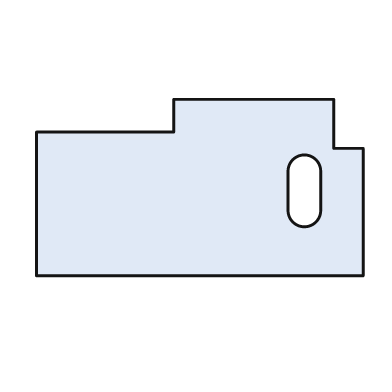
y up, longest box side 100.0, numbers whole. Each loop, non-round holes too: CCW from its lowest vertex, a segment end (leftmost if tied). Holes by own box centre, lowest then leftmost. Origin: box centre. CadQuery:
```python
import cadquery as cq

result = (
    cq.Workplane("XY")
    .moveTo(-50.0, -27.0)
    .lineTo(50.0, -27.0)
    .lineTo(50.0, 12.0)
    .lineTo(41.0, 12.0)
    .lineTo(41.0, 27.0)
    .lineTo(-8.0, 27.0)
    .lineTo(-8.0, 17.0)
    .lineTo(-50.0, 17.0)
    .close()
    .moveTo(27.0, -7.0)
    .threePointArc((32.0, -12.0), (37.0, -7.0))
    .lineTo(37.0, 5.0)
    .threePointArc((32.0, 10.0), (27.0, 5.0))
    .close()
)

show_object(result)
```